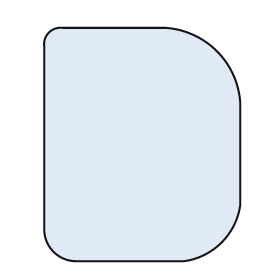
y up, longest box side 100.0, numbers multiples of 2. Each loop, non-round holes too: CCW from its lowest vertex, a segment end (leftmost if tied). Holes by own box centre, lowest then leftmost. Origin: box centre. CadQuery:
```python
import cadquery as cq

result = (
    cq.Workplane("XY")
    .moveTo(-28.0, -50.0)
    .lineTo(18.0, -50.0)
    .threePointArc((34.0, -42.0), (42.0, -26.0))
    .lineTo(42.0, 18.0)
    .threePointArc((32.0, 40.0), (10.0, 50.0))
    .lineTo(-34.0, 50.0)
    .threePointArc((-40.0, 48.0), (-42.0, 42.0))
    .lineTo(-42.0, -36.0)
    .threePointArc((-38.0, -46.0), (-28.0, -50.0))
    .close()
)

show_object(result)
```